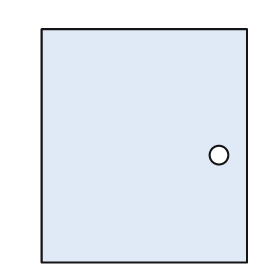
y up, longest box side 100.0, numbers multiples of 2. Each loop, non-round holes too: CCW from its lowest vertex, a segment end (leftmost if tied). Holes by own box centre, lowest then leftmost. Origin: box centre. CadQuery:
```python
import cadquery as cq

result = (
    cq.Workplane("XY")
    .moveTo(-44.0, -50.0)
    .lineTo(44.0, -50.0)
    .lineTo(44.0, 50.0)
    .lineTo(-44.0, 50.0)
    .close()
    .moveTo(32.0, -4.0)
    .circle(4.0)
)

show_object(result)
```